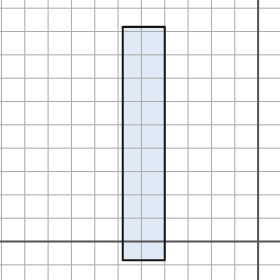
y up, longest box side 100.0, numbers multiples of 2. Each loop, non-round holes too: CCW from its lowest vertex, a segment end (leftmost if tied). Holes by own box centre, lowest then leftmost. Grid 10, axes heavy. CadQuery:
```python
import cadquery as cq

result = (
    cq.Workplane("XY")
    .moveTo(-58.0, -8.0)
    .lineTo(-40.0, -8.0)
    .lineTo(-40.0, 92.0)
    .lineTo(-58.0, 92.0)
    .close()
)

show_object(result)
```